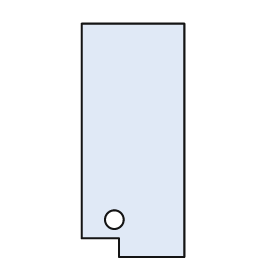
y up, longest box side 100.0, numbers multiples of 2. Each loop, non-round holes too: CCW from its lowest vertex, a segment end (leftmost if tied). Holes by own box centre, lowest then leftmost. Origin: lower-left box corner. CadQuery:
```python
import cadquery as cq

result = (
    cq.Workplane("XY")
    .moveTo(16.0, 0.0)
    .lineTo(44.0, 0.0)
    .lineTo(44.0, 100.0)
    .lineTo(0.0, 100.0)
    .lineTo(0.0, 8.0)
    .lineTo(16.0, 8.0)
    .close()
    .moveTo(14.0, 16.0)
    .circle(4.0)
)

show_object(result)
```